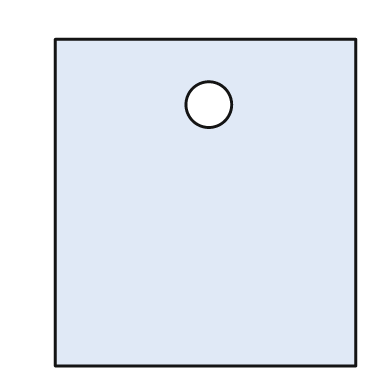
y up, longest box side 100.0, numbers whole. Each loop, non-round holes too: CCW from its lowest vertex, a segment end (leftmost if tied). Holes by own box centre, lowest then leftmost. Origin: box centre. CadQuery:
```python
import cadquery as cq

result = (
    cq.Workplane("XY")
    .moveTo(-46.0, -50.0)
    .lineTo(46.0, -50.0)
    .lineTo(46.0, 50.0)
    .lineTo(-46.0, 50.0)
    .close()
    .moveTo(1.0, 30.0)
    .circle(7.0)
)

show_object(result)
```